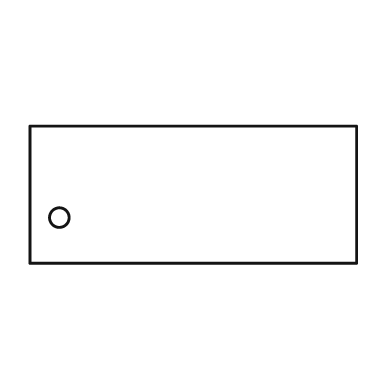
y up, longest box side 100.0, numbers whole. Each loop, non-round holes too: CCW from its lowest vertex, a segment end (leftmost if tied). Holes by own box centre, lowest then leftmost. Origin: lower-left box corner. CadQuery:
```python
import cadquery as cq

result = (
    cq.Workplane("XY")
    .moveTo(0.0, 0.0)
    .lineTo(100.0, 0.0)
    .lineTo(100.0, 42.0)
    .lineTo(0.0, 42.0)
    .close()
    .moveTo(9.0, 14.0)
    .circle(3.0)
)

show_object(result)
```